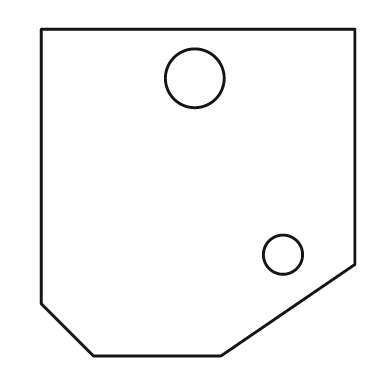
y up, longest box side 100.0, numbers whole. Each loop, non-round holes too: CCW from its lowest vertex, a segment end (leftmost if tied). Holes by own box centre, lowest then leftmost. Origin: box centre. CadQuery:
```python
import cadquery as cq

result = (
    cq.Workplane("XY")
    .moveTo(-32.0, -50.0)
    .lineTo(7.0, -50.0)
    .lineTo(48.0, -22.0)
    .lineTo(48.0, 50.0)
    .lineTo(-48.0, 50.0)
    .lineTo(-48.0, -34.0)
    .close()
    .moveTo(26.0, -19.0)
    .circle(6.0)
    .moveTo(-1.0, 35.0)
    .circle(9.0)
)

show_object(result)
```